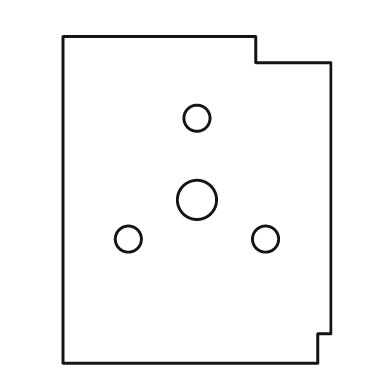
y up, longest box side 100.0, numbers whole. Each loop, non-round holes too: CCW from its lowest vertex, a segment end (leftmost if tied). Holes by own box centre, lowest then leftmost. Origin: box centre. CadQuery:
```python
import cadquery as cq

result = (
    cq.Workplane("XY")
    .moveTo(-41.0, -50.0)
    .lineTo(37.0, -50.0)
    .lineTo(37.0, -41.0)
    .lineTo(41.0, -41.0)
    .lineTo(41.0, 42.0)
    .lineTo(18.0, 42.0)
    .lineTo(18.0, 50.0)
    .lineTo(-41.0, 50.0)
    .close()
    .moveTo(-21.0, -12.0)
    .circle(4.0)
    .moveTo(21.0, -12.0)
    .circle(4.0)
    .moveTo(0.0, 0.0)
    .circle(6.0)
    .moveTo(0.0, 25.0)
    .circle(4.0)
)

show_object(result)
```